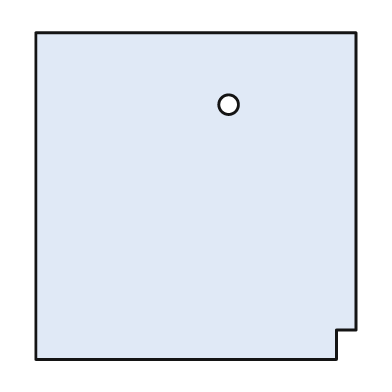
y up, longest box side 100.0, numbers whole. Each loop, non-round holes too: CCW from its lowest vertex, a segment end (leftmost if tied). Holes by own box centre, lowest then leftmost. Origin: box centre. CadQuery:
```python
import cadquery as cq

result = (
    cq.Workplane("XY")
    .moveTo(-49.0, -50.0)
    .lineTo(43.0, -50.0)
    .lineTo(43.0, -41.0)
    .lineTo(49.0, -41.0)
    .lineTo(49.0, 50.0)
    .lineTo(-49.0, 50.0)
    .close()
    .moveTo(10.0, 28.0)
    .circle(3.0)
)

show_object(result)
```